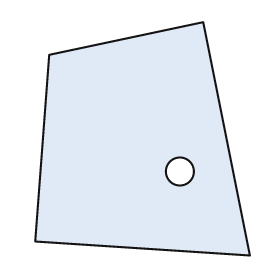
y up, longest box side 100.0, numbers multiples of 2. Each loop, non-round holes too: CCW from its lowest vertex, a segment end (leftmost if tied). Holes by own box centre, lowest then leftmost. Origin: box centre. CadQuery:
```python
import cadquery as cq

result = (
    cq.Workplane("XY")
    .moveTo(46.0, -50.0)
    .lineTo(26.0, 50.0)
    .lineTo(-40.0, 36.0)
    .lineTo(-46.0, -44.0)
    .close()
    .moveTo(16.0, -14.0)
    .circle(6.0)
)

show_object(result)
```